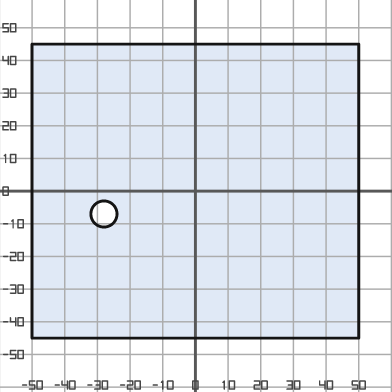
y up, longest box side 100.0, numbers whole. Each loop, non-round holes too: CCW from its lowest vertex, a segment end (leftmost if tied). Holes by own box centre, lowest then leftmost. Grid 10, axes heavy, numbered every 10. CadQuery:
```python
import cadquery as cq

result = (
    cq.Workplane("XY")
    .moveTo(-50.0, -45.0)
    .lineTo(50.0, -45.0)
    .lineTo(50.0, 45.0)
    .lineTo(-50.0, 45.0)
    .close()
    .moveTo(-28.0, -7.0)
    .circle(4.0)
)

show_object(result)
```